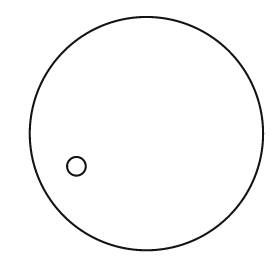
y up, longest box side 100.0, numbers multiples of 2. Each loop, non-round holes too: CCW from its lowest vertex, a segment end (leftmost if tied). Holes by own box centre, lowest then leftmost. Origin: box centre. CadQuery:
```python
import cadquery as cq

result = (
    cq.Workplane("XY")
    .moveTo(0.0, 0.0)
    .circle(50.0)
    .moveTo(-30.0, -14.0)
    .circle(4.0)
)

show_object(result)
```